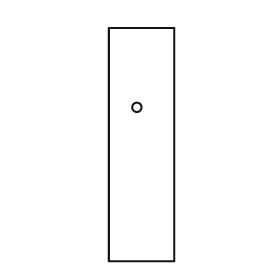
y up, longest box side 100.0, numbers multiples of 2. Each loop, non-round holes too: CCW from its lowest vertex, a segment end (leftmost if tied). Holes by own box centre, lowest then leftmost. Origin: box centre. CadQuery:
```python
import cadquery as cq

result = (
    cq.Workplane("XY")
    .moveTo(-14.0, -50.0)
    .lineTo(14.0, -50.0)
    .lineTo(14.0, 50.0)
    .lineTo(-14.0, 50.0)
    .close()
    .moveTo(-2.0, 16.0)
    .circle(2.0)
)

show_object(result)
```